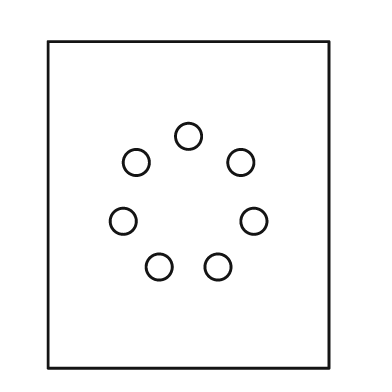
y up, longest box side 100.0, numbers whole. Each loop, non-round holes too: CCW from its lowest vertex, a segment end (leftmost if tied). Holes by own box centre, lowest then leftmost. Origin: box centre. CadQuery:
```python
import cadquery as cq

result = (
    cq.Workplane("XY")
    .moveTo(-43.0, -50.0)
    .lineTo(43.0, -50.0)
    .lineTo(43.0, 50.0)
    .lineTo(-43.0, 50.0)
    .close()
    .moveTo(-9.0, -19.0)
    .circle(4.0)
    .moveTo(9.0, -19.0)
    .circle(4.0)
    .moveTo(-20.0, -5.0)
    .circle(4.0)
    .moveTo(20.0, -5.0)
    .circle(4.0)
    .moveTo(-16.0, 13.0)
    .circle(4.0)
    .moveTo(16.0, 13.0)
    .circle(4.0)
    .moveTo(0.0, 21.0)
    .circle(4.0)
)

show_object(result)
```